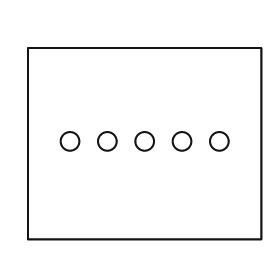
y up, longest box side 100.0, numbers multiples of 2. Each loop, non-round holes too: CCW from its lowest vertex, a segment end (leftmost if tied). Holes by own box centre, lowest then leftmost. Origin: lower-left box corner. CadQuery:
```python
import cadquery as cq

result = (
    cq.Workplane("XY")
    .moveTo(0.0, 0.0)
    .lineTo(100.0, 0.0)
    .lineTo(100.0, 82.0)
    .lineTo(0.0, 82.0)
    .close()
    .moveTo(18.0, 42.0)
    .circle(4.0)
    .moveTo(34.0, 42.0)
    .circle(4.0)
    .moveTo(50.0, 42.0)
    .circle(4.0)
    .moveTo(66.0, 42.0)
    .circle(4.0)
    .moveTo(82.0, 42.0)
    .circle(4.0)
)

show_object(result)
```